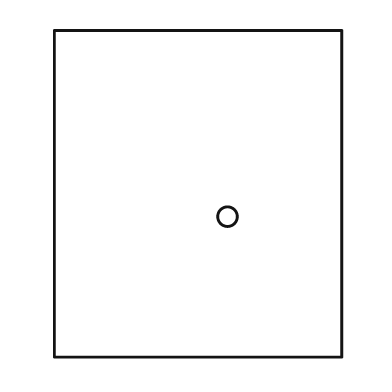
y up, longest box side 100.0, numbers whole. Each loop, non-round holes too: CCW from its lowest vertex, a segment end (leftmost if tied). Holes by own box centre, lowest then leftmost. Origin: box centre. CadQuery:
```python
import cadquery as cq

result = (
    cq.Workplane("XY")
    .moveTo(-44.0, -50.0)
    .lineTo(44.0, -50.0)
    .lineTo(44.0, 50.0)
    .lineTo(-44.0, 50.0)
    .close()
    .moveTo(9.0, -7.0)
    .circle(3.0)
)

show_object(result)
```